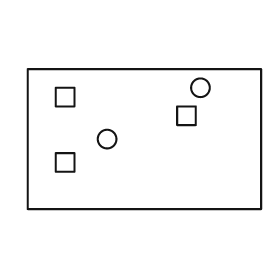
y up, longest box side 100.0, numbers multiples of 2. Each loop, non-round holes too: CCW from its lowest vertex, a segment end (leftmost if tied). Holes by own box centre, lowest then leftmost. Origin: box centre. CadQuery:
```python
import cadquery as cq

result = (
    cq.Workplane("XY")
    .moveTo(-50.0, -30.0)
    .lineTo(50.0, -30.0)
    .lineTo(50.0, 30.0)
    .lineTo(-50.0, 30.0)
    .close()
    .moveTo(-38.0, -14.0)
    .lineTo(-30.0, -14.0)
    .lineTo(-30.0, -6.0)
    .lineTo(-38.0, -6.0)
    .close()
    .moveTo(-16.0, 0.0)
    .circle(4.0)
    .moveTo(14.0, 6.0)
    .lineTo(22.0, 6.0)
    .lineTo(22.0, 14.0)
    .lineTo(14.0, 14.0)
    .close()
    .moveTo(-38.0, 14.0)
    .lineTo(-30.0, 14.0)
    .lineTo(-30.0, 22.0)
    .lineTo(-38.0, 22.0)
    .close()
    .moveTo(24.0, 22.0)
    .circle(4.0)
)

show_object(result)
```